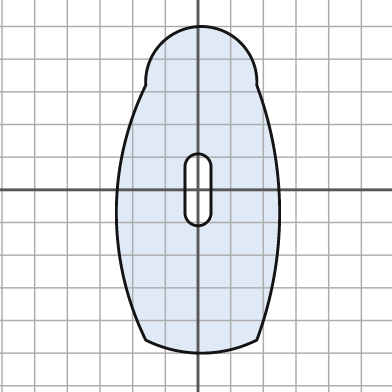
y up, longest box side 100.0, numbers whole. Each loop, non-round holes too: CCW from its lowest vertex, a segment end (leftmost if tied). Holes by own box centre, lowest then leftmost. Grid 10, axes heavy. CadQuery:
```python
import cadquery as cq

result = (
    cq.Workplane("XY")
    .moveTo(-16.0, -46.0)
    .threePointArc((1.0, -50.0), (18.0, -46.0))
    .threePointArc((25.0, -7.0), (18.0, 32.0))
    .threePointArc((1.0, 50.0), (-16.0, 32.0))
    .threePointArc((-25.0, -7.0), (-16.0, -46.0))
    .close()
    .moveTo(-4.0, -7.0)
    .threePointArc((0.0, -11.0), (4.0, -7.0))
    .lineTo(4.0, 7.0)
    .threePointArc((0.0, 11.0), (-4.0, 7.0))
    .close()
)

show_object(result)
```